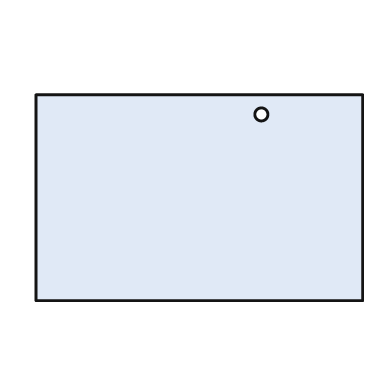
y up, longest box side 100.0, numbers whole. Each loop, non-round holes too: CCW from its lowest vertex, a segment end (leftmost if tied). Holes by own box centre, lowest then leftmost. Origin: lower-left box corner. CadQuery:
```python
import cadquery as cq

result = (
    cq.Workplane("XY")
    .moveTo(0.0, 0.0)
    .lineTo(100.0, 0.0)
    .lineTo(100.0, 63.0)
    .lineTo(0.0, 63.0)
    .close()
    .moveTo(69.0, 57.0)
    .circle(2.0)
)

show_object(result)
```